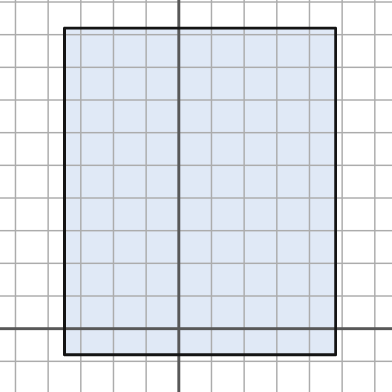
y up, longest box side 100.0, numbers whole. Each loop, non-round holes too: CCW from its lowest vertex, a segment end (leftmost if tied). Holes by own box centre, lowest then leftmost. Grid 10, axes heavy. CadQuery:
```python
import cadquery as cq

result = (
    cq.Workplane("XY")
    .moveTo(-35.0, -8.0)
    .lineTo(48.0, -8.0)
    .lineTo(48.0, 92.0)
    .lineTo(-35.0, 92.0)
    .close()
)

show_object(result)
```